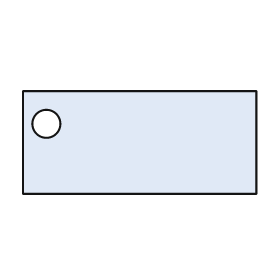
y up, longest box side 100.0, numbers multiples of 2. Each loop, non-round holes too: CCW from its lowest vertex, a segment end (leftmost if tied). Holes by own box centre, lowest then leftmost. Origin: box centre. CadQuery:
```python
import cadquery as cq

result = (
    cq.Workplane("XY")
    .moveTo(-50.0, -22.0)
    .lineTo(50.0, -22.0)
    .lineTo(50.0, 22.0)
    .lineTo(-50.0, 22.0)
    .close()
    .moveTo(-40.0, 8.0)
    .circle(6.0)
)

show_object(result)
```